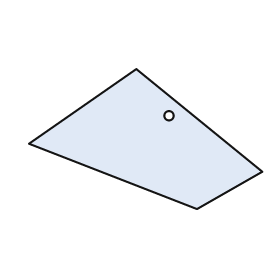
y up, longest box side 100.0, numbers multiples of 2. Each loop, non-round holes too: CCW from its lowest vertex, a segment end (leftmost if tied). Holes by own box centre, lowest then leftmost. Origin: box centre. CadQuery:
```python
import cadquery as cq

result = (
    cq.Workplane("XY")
    .moveTo(22.0, -30.0)
    .lineTo(50.0, -14.0)
    .lineTo(-4.0, 30.0)
    .lineTo(-50.0, -2.0)
    .close()
    .moveTo(10.0, 10.0)
    .circle(2.0)
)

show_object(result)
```